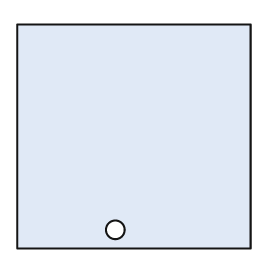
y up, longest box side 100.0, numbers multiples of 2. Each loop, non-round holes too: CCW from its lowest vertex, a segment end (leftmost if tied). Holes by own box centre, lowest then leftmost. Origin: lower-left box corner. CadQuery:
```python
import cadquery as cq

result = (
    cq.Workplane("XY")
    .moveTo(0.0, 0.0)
    .lineTo(100.0, 0.0)
    .lineTo(100.0, 96.0)
    .lineTo(0.0, 96.0)
    .close()
    .moveTo(42.0, 8.0)
    .circle(4.0)
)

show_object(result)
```